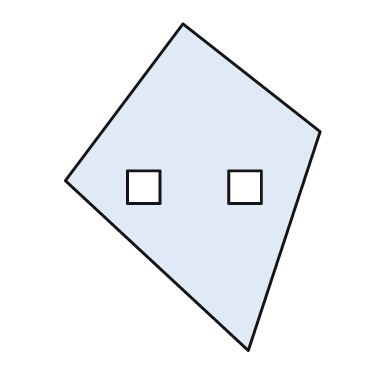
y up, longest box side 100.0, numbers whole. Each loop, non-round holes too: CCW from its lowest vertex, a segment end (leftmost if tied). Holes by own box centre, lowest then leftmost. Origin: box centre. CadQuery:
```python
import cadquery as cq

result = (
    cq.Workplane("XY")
    .moveTo(17.0, -50.0)
    .lineTo(39.0, 17.0)
    .lineTo(-3.0, 50.0)
    .lineTo(-39.0, 2.0)
    .close()
    .moveTo(-20.0, -5.0)
    .lineTo(-10.0, -5.0)
    .lineTo(-10.0, 5.0)
    .lineTo(-20.0, 5.0)
    .close()
    .moveTo(11.0, -5.0)
    .lineTo(21.0, -5.0)
    .lineTo(21.0, 5.0)
    .lineTo(11.0, 5.0)
    .close()
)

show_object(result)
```